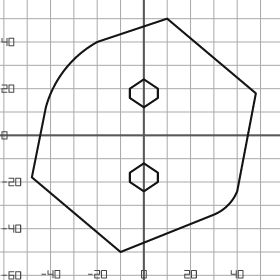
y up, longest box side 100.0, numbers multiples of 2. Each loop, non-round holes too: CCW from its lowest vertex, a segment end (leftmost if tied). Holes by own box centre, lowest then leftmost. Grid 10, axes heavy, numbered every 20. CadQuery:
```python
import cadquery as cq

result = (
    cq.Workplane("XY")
    .moveTo(-10.0, -50.0)
    .lineTo(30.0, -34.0)
    .threePointArc((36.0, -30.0), (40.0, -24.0))
    .lineTo(48.0, 18.0)
    .lineTo(10.0, 50.0)
    .lineTo(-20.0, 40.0)
    .threePointArc((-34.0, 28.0), (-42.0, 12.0))
    .lineTo(-48.0, -18.0)
    .close()
    .moveTo(0.0, -24.0)
    .lineTo(6.0, -20.0)
    .lineTo(6.0, -16.0)
    .lineTo(0.0, -12.0)
    .lineTo(-6.0, -16.0)
    .lineTo(-6.0, -20.0)
    .close()
    .moveTo(0.0, 12.0)
    .lineTo(6.0, 16.0)
    .lineTo(6.0, 20.0)
    .lineTo(0.0, 24.0)
    .lineTo(-6.0, 20.0)
    .lineTo(-6.0, 16.0)
    .close()
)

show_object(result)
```